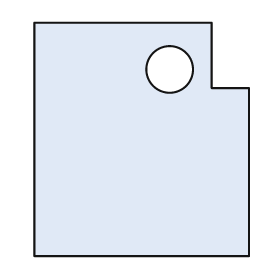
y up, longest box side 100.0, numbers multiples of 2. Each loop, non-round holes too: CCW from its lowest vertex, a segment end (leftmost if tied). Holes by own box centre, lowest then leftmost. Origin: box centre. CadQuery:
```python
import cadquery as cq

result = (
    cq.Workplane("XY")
    .moveTo(-46.0, -50.0)
    .lineTo(46.0, -50.0)
    .lineTo(46.0, 22.0)
    .lineTo(30.0, 22.0)
    .lineTo(30.0, 50.0)
    .lineTo(-46.0, 50.0)
    .close()
    .moveTo(12.0, 30.0)
    .circle(10.0)
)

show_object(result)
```